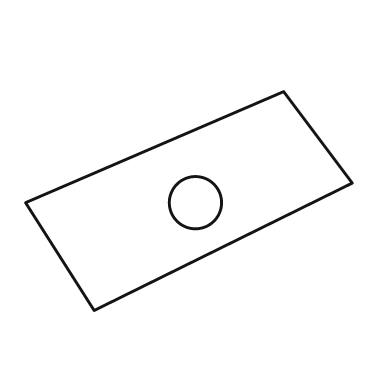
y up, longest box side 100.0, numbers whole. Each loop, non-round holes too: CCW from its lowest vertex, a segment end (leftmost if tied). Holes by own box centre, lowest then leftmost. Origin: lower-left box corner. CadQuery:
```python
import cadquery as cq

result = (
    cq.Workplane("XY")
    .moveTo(21.0, 0.0)
    .lineTo(100.0, 39.0)
    .lineTo(79.0, 67.0)
    .lineTo(0.0, 33.0)
    .close()
    .moveTo(52.0, 33.0)
    .circle(8.0)
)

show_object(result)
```